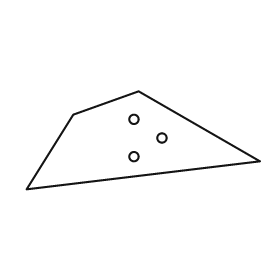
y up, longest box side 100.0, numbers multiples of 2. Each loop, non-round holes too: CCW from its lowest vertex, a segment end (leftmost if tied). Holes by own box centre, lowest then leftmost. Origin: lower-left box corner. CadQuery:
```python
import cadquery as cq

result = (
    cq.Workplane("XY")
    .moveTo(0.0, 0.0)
    .lineTo(100.0, 12.0)
    .lineTo(48.0, 42.0)
    .lineTo(20.0, 32.0)
    .close()
    .moveTo(46.0, 14.0)
    .circle(2.0)
    .moveTo(58.0, 22.0)
    .circle(2.0)
    .moveTo(46.0, 30.0)
    .circle(2.0)
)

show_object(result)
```